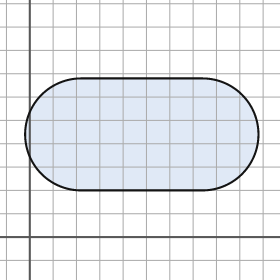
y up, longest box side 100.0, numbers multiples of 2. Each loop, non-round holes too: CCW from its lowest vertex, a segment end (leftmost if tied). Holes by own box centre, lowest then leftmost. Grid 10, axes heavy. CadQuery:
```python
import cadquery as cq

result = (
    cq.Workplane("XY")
    .moveTo(22.0, 20.0)
    .lineTo(74.0, 20.0)
    .threePointArc((98.0, 44.0), (74.0, 68.0))
    .lineTo(22.0, 68.0)
    .threePointArc((-2.0, 44.0), (22.0, 20.0))
    .close()
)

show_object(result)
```